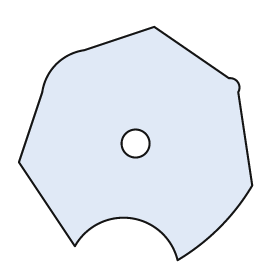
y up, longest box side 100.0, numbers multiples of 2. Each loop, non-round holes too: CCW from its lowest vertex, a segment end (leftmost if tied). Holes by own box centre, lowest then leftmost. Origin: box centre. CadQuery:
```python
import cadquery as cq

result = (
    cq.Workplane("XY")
    .moveTo(18.0, -50.0)
    .threePointArc((36.0, -36.0), (50.0, -18.0))
    .lineTo(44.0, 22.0)
    .threePointArc((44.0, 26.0), (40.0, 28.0))
    .lineTo(8.0, 50.0)
    .lineTo(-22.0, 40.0)
    .threePointArc((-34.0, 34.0), (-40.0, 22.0))
    .lineTo(-50.0, -8.0)
    .lineTo(-26.0, -44.0)
    .threePointArc((-2.0, -32.0), (18.0, -50.0))
    .close()
    .moveTo(0.0, 0.0)
    .circle(6.0)
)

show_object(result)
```